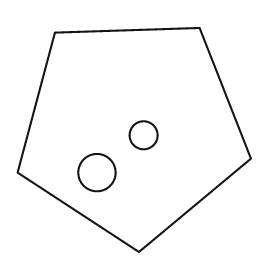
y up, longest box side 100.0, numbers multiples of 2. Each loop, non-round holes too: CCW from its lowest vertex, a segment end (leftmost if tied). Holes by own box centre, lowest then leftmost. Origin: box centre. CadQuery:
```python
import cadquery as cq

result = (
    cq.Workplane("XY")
    .moveTo(2.0, -48.0)
    .lineTo(50.0, -8.0)
    .lineTo(28.0, 48.0)
    .lineTo(-34.0, 46.0)
    .lineTo(-50.0, -14.0)
    .close()
    .moveTo(-16.0, -14.0)
    .circle(8.0)
    .moveTo(4.0, 2.0)
    .circle(6.0)
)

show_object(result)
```